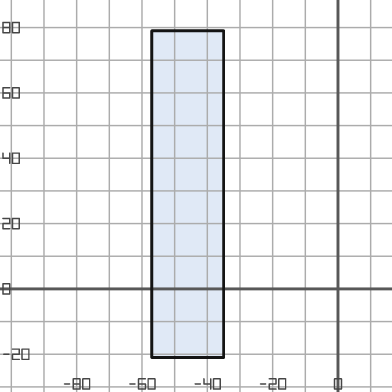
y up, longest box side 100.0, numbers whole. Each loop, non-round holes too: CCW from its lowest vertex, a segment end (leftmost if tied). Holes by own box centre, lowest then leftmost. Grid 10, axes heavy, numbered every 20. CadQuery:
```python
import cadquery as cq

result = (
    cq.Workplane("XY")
    .moveTo(-57.0, -21.0)
    .lineTo(-35.0, -21.0)
    .lineTo(-35.0, 79.0)
    .lineTo(-57.0, 79.0)
    .close()
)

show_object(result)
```